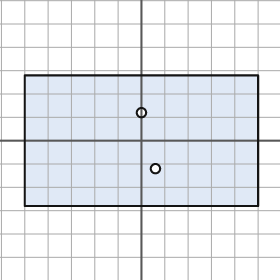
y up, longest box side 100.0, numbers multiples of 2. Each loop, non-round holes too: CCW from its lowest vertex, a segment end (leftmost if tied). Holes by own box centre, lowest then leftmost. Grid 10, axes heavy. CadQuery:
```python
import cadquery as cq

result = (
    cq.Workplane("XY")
    .moveTo(-50.0, -28.0)
    .lineTo(50.0, -28.0)
    .lineTo(50.0, 28.0)
    .lineTo(-50.0, 28.0)
    .close()
    .moveTo(6.0, -12.0)
    .circle(2.0)
    .moveTo(0.0, 12.0)
    .circle(2.0)
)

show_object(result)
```